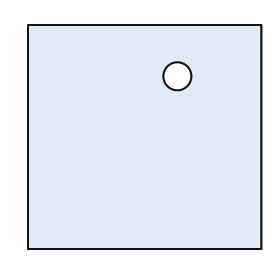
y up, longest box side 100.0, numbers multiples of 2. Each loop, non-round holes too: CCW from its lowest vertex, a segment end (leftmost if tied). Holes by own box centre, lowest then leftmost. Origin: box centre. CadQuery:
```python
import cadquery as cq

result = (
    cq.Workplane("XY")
    .moveTo(-50.0, -48.0)
    .lineTo(50.0, -48.0)
    .lineTo(50.0, 48.0)
    .lineTo(-50.0, 48.0)
    .close()
    .moveTo(14.0, 26.0)
    .circle(6.0)
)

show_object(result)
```